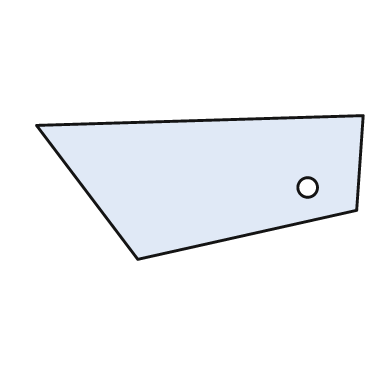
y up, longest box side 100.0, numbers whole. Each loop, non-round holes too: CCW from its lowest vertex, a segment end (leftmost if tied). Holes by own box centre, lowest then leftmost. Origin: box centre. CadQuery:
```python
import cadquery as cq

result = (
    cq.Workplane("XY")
    .moveTo(-19.0, -22.0)
    .lineTo(48.0, -7.0)
    .lineTo(50.0, 22.0)
    .lineTo(-50.0, 19.0)
    .close()
    .moveTo(33.0, 0.0)
    .circle(3.0)
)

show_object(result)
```